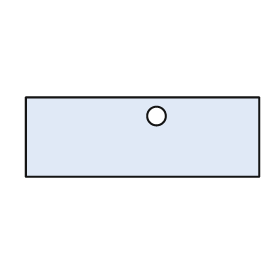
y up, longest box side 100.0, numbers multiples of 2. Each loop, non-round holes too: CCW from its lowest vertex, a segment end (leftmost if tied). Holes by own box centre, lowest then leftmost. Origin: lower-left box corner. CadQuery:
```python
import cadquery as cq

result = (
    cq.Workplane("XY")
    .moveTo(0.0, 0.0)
    .lineTo(100.0, 0.0)
    .lineTo(100.0, 34.0)
    .lineTo(0.0, 34.0)
    .close()
    .moveTo(56.0, 26.0)
    .circle(4.0)
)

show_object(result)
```